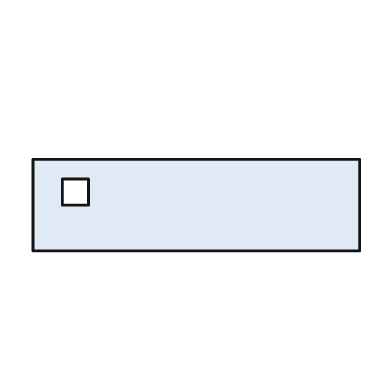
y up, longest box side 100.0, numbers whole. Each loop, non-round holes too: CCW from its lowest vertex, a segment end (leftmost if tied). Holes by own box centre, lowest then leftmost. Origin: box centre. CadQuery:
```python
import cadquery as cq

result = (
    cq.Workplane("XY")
    .moveTo(-50.0, -14.0)
    .lineTo(50.0, -14.0)
    .lineTo(50.0, 14.0)
    .lineTo(-50.0, 14.0)
    .close()
    .moveTo(-41.0, 0.0)
    .lineTo(-33.0, 0.0)
    .lineTo(-33.0, 8.0)
    .lineTo(-41.0, 8.0)
    .close()
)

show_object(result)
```